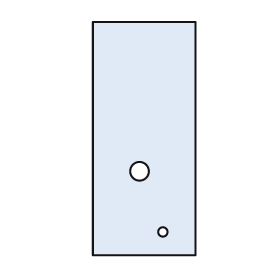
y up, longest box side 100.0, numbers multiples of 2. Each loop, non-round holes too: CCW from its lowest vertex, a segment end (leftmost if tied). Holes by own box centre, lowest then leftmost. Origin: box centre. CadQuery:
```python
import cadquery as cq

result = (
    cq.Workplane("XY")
    .moveTo(-22.0, -50.0)
    .lineTo(22.0, -50.0)
    .lineTo(22.0, 50.0)
    .lineTo(-22.0, 50.0)
    .close()
    .moveTo(8.0, -40.0)
    .circle(2.0)
    .moveTo(-2.0, -14.0)
    .circle(4.0)
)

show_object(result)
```